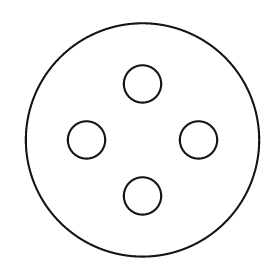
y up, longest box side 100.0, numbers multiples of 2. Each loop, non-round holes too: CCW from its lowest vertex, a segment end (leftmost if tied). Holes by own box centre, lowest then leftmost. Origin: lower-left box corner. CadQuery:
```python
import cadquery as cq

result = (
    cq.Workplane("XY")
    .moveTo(50.0, 50.0)
    .circle(50.0)
    .moveTo(50.0, 26.0)
    .circle(8.0)
    .moveTo(26.0, 50.0)
    .circle(8.0)
    .moveTo(74.0, 50.0)
    .circle(8.0)
    .moveTo(50.0, 74.0)
    .circle(8.0)
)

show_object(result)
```